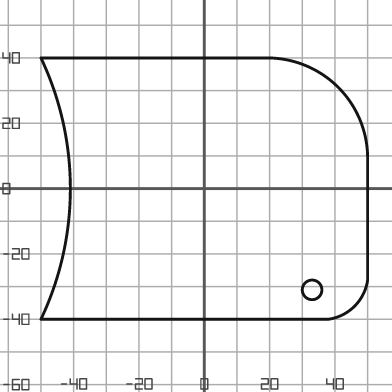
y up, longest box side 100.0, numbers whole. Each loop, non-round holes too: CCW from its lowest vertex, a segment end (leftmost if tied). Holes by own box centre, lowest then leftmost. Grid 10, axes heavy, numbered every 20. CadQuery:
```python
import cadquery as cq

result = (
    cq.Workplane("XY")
    .moveTo(-50.0, -40.0)
    .lineTo(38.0, -40.0)
    .threePointArc((46.0, -36.0), (50.0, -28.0))
    .lineTo(50.0, 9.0)
    .threePointArc((41.0, 31.0), (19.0, 40.0))
    .lineTo(-50.0, 40.0)
    .threePointArc((-41.0, 0.0), (-50.0, -40.0))
    .close()
    .moveTo(33.0, -31.0)
    .circle(3.0)
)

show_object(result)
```